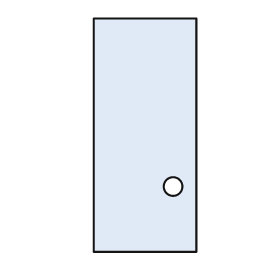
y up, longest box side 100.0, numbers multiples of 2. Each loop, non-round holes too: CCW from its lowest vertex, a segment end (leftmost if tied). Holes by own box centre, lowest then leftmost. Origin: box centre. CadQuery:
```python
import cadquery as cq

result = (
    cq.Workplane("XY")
    .moveTo(-22.0, -50.0)
    .lineTo(22.0, -50.0)
    .lineTo(22.0, 50.0)
    .lineTo(-22.0, 50.0)
    .close()
    .moveTo(12.0, -22.0)
    .circle(4.0)
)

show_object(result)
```